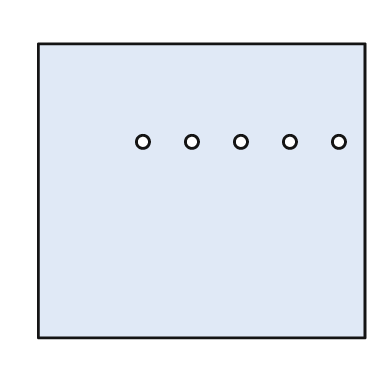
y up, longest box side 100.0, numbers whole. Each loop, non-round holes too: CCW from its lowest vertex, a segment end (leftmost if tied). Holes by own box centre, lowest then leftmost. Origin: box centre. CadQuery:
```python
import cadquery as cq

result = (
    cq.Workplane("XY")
    .moveTo(-50.0, -45.0)
    .lineTo(50.0, -45.0)
    .lineTo(50.0, 45.0)
    .lineTo(-50.0, 45.0)
    .close()
    .moveTo(-18.0, 15.0)
    .circle(2.0)
    .moveTo(-3.0, 15.0)
    .circle(2.0)
    .moveTo(12.0, 15.0)
    .circle(2.0)
    .moveTo(27.0, 15.0)
    .circle(2.0)
    .moveTo(42.0, 15.0)
    .circle(2.0)
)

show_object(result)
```